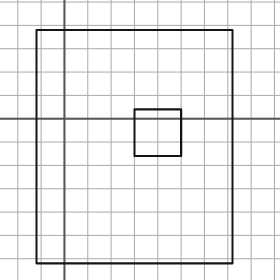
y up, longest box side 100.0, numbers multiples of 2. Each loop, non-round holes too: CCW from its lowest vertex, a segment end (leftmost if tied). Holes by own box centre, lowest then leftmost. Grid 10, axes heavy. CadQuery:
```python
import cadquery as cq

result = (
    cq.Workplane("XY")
    .moveTo(-12.0, -62.0)
    .lineTo(72.0, -62.0)
    .lineTo(72.0, 38.0)
    .lineTo(-12.0, 38.0)
    .close()
    .moveTo(30.0, -16.0)
    .lineTo(50.0, -16.0)
    .lineTo(50.0, 4.0)
    .lineTo(30.0, 4.0)
    .close()
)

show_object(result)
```